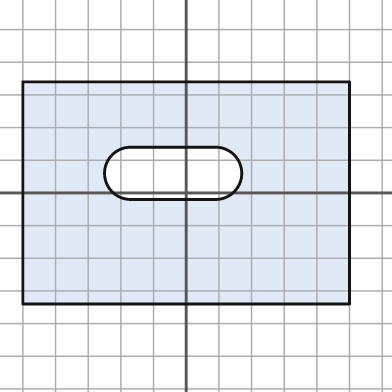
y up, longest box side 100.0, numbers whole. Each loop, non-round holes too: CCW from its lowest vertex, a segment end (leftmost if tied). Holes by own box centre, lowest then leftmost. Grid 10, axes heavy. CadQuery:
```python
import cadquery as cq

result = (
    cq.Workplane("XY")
    .moveTo(-50.0, -34.0)
    .lineTo(50.0, -34.0)
    .lineTo(50.0, 34.0)
    .lineTo(-50.0, 34.0)
    .close()
    .moveTo(-17.0, -2.0)
    .lineTo(9.0, -2.0)
    .threePointArc((17.0, 6.0), (9.0, 14.0))
    .lineTo(-17.0, 14.0)
    .threePointArc((-25.0, 6.0), (-17.0, -2.0))
    .close()
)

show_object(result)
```